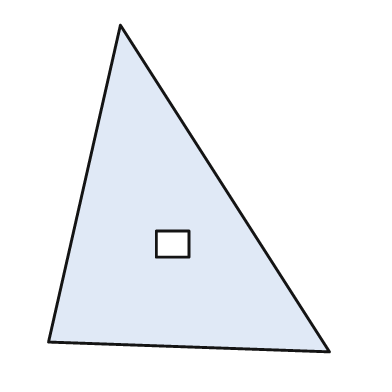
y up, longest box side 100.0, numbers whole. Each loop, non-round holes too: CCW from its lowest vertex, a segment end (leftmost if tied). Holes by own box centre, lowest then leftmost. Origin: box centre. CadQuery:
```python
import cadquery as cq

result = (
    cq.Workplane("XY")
    .moveTo(43.0, -50.0)
    .lineTo(-21.0, 50.0)
    .lineTo(-43.0, -47.0)
    .close()
    .moveTo(-10.0, -21.0)
    .lineTo(0.0, -21.0)
    .lineTo(0.0, -13.0)
    .lineTo(-10.0, -13.0)
    .close()
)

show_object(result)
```